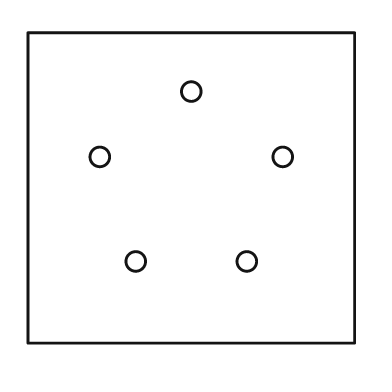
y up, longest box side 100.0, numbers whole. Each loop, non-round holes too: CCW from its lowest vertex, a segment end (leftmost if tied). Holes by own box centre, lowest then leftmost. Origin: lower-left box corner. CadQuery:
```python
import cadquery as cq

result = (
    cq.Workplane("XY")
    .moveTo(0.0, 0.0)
    .lineTo(100.0, 0.0)
    .lineTo(100.0, 95.0)
    .lineTo(0.0, 95.0)
    .close()
    .moveTo(33.0, 25.0)
    .circle(3.0)
    .moveTo(67.0, 25.0)
    .circle(3.0)
    .moveTo(22.0, 57.0)
    .circle(3.0)
    .moveTo(78.0, 57.0)
    .circle(3.0)
    .moveTo(50.0, 77.0)
    .circle(3.0)
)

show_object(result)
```